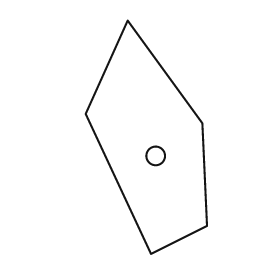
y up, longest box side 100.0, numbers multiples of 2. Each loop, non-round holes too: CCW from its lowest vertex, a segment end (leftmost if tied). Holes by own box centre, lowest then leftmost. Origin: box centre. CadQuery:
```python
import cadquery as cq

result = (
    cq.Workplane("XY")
    .moveTo(2.0, -50.0)
    .lineTo(26.0, -38.0)
    .lineTo(24.0, 6.0)
    .lineTo(-8.0, 50.0)
    .lineTo(-26.0, 10.0)
    .close()
    .moveTo(4.0, -8.0)
    .circle(4.0)
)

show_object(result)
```